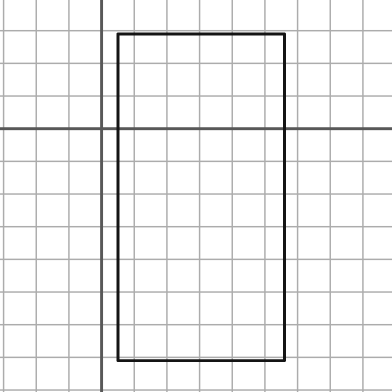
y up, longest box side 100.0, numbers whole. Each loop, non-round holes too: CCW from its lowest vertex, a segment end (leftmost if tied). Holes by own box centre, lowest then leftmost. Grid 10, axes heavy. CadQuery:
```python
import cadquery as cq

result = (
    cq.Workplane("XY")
    .moveTo(5.0, -71.0)
    .lineTo(56.0, -71.0)
    .lineTo(56.0, 29.0)
    .lineTo(5.0, 29.0)
    .close()
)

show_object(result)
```